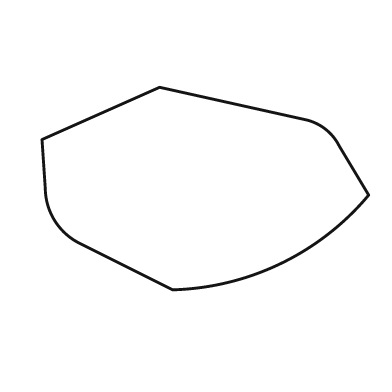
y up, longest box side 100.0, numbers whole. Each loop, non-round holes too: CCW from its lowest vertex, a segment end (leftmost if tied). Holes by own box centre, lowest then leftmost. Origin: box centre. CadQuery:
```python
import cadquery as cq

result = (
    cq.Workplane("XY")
    .moveTo(-10.0, -31.0)
    .threePointArc((23.0, -23.0), (50.0, -2.0))
    .lineTo(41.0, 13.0)
    .threePointArc((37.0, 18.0), (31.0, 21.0))
    .lineTo(-14.0, 31.0)
    .lineTo(-50.0, 15.0)
    .lineTo(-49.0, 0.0)
    .threePointArc((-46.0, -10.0), (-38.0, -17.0))
    .close()
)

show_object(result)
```